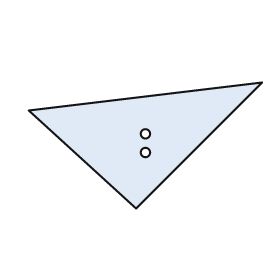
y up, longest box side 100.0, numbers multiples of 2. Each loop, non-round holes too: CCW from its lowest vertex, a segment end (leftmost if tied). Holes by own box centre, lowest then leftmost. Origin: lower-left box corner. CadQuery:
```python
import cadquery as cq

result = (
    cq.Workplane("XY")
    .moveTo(46.0, 0.0)
    .lineTo(100.0, 54.0)
    .lineTo(0.0, 42.0)
    .close()
    .moveTo(50.0, 24.0)
    .circle(2.0)
    .moveTo(50.0, 32.0)
    .circle(2.0)
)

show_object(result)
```